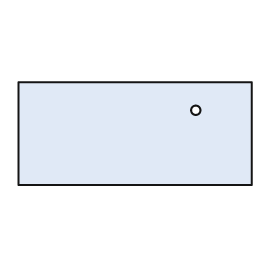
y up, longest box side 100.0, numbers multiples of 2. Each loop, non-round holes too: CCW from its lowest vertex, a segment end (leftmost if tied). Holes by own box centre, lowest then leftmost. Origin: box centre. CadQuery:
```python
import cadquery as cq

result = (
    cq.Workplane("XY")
    .moveTo(-50.0, -22.0)
    .lineTo(50.0, -22.0)
    .lineTo(50.0, 22.0)
    .lineTo(-50.0, 22.0)
    .close()
    .moveTo(26.0, 10.0)
    .circle(2.0)
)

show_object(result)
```